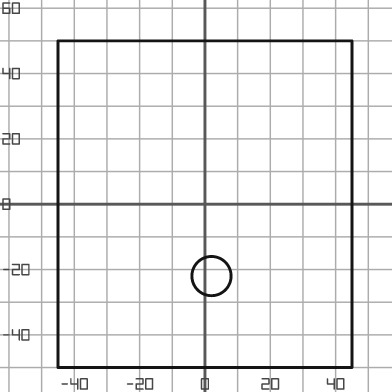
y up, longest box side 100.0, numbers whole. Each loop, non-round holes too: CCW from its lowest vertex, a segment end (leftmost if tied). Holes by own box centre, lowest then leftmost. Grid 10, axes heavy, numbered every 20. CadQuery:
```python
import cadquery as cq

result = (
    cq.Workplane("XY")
    .moveTo(-45.0, -50.0)
    .lineTo(45.0, -50.0)
    .lineTo(45.0, 50.0)
    .lineTo(-45.0, 50.0)
    .close()
    .moveTo(2.0, -22.0)
    .circle(6.0)
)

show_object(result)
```